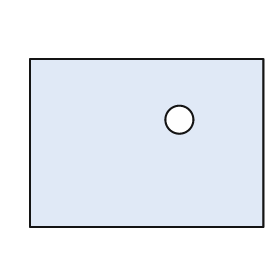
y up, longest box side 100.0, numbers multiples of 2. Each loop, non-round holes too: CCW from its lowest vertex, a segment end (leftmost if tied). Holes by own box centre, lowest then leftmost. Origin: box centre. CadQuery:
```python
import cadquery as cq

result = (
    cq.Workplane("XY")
    .moveTo(-50.0, -36.0)
    .lineTo(50.0, -36.0)
    .lineTo(50.0, 36.0)
    .lineTo(-50.0, 36.0)
    .close()
    .moveTo(14.0, 10.0)
    .circle(6.0)
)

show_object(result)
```